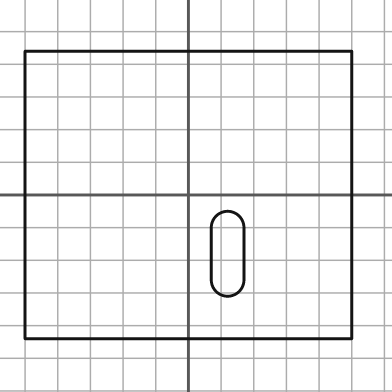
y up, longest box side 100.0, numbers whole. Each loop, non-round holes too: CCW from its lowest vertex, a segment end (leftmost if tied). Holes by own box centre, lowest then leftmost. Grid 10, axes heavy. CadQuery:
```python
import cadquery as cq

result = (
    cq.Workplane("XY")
    .moveTo(-50.0, -44.0)
    .lineTo(50.0, -44.0)
    .lineTo(50.0, 44.0)
    .lineTo(-50.0, 44.0)
    .close()
    .moveTo(7.0, -26.0)
    .threePointArc((12.0, -31.0), (17.0, -26.0))
    .lineTo(17.0, -10.0)
    .threePointArc((12.0, -5.0), (7.0, -10.0))
    .close()
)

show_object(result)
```